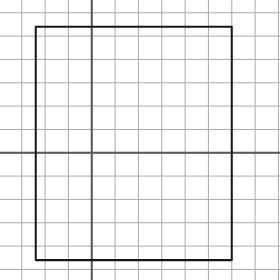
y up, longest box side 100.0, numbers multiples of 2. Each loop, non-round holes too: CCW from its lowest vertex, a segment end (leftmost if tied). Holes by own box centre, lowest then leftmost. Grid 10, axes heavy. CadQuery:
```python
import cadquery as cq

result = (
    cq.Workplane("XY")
    .moveTo(-24.0, -46.0)
    .lineTo(60.0, -46.0)
    .lineTo(60.0, 54.0)
    .lineTo(-24.0, 54.0)
    .close()
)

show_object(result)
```